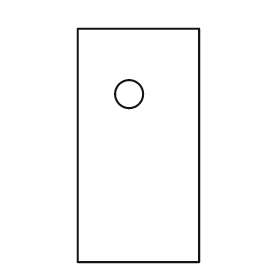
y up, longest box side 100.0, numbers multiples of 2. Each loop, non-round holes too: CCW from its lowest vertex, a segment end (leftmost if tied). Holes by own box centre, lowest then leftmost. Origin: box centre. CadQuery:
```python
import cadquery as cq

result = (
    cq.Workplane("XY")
    .moveTo(-26.0, -50.0)
    .lineTo(26.0, -50.0)
    .lineTo(26.0, 50.0)
    .lineTo(-26.0, 50.0)
    .close()
    .moveTo(-4.0, 22.0)
    .circle(6.0)
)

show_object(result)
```